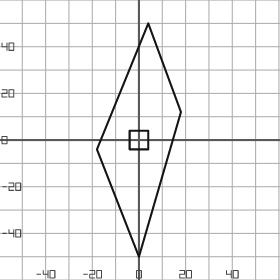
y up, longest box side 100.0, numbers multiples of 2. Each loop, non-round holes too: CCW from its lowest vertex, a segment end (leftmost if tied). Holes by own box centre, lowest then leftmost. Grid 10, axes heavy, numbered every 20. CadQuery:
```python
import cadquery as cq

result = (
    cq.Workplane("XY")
    .moveTo(0.0, -50.0)
    .lineTo(18.0, 12.0)
    .lineTo(4.0, 50.0)
    .lineTo(-18.0, -4.0)
    .close()
    .moveTo(-4.0, -4.0)
    .lineTo(4.0, -4.0)
    .lineTo(4.0, 4.0)
    .lineTo(-4.0, 4.0)
    .close()
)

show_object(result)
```